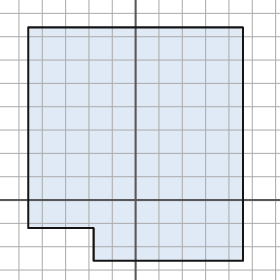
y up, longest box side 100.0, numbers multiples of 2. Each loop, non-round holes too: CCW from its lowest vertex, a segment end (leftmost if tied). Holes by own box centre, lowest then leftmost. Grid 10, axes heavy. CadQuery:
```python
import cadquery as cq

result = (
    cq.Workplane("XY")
    .moveTo(-18.0, -26.0)
    .lineTo(46.0, -26.0)
    .lineTo(46.0, 74.0)
    .lineTo(-46.0, 74.0)
    .lineTo(-46.0, -12.0)
    .lineTo(-18.0, -12.0)
    .close()
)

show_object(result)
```